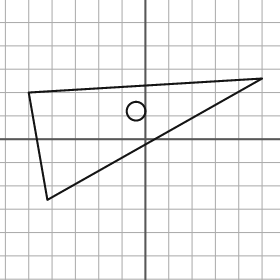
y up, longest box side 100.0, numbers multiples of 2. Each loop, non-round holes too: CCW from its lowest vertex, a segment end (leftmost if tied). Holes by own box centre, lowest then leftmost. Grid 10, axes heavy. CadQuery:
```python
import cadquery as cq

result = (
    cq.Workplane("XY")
    .moveTo(-42.0, -26.0)
    .lineTo(50.0, 26.0)
    .lineTo(-50.0, 20.0)
    .close()
    .moveTo(-4.0, 12.0)
    .circle(4.0)
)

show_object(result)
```